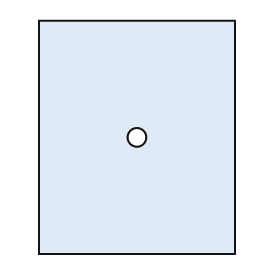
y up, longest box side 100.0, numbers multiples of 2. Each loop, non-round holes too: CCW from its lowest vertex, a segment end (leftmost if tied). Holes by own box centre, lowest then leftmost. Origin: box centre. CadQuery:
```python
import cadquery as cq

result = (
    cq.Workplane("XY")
    .moveTo(-42.0, -50.0)
    .lineTo(42.0, -50.0)
    .lineTo(42.0, 50.0)
    .lineTo(-42.0, 50.0)
    .close()
    .moveTo(0.0, 0.0)
    .circle(4.0)
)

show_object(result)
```